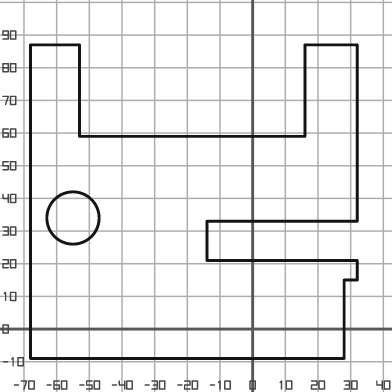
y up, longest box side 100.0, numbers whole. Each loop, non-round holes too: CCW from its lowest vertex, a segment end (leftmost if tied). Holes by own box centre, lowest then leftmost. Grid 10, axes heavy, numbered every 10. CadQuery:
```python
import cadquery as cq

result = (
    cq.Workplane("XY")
    .moveTo(-68.0, -9.0)
    .lineTo(28.0, -9.0)
    .lineTo(28.0, 15.0)
    .lineTo(32.0, 15.0)
    .lineTo(32.0, 21.0)
    .lineTo(-14.0, 21.0)
    .lineTo(-14.0, 33.0)
    .lineTo(32.0, 33.0)
    .lineTo(32.0, 87.0)
    .lineTo(16.0, 87.0)
    .lineTo(16.0, 59.0)
    .lineTo(-53.0, 59.0)
    .lineTo(-53.0, 87.0)
    .lineTo(-68.0, 87.0)
    .close()
    .moveTo(-55.0, 34.0)
    .circle(8.0)
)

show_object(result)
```